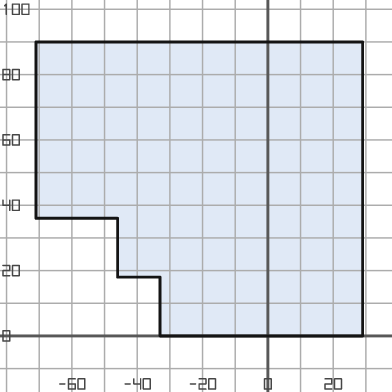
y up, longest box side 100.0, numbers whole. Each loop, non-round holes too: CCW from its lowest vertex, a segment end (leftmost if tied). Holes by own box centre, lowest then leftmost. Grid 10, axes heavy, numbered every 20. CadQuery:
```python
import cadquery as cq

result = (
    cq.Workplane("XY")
    .moveTo(-33.0, 0.0)
    .lineTo(29.0, 0.0)
    .lineTo(29.0, 90.0)
    .lineTo(-71.0, 90.0)
    .lineTo(-71.0, 36.0)
    .lineTo(-46.0, 36.0)
    .lineTo(-46.0, 18.0)
    .lineTo(-33.0, 18.0)
    .close()
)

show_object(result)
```